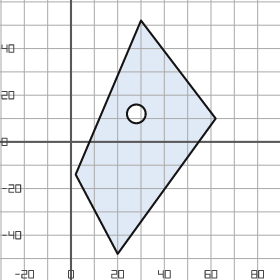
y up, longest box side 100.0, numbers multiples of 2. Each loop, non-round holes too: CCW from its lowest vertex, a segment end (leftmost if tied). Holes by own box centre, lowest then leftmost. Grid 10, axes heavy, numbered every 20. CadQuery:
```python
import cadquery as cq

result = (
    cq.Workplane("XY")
    .moveTo(20.0, -48.0)
    .lineTo(62.0, 10.0)
    .lineTo(30.0, 52.0)
    .lineTo(2.0, -14.0)
    .close()
    .moveTo(28.0, 12.0)
    .circle(4.0)
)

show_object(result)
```